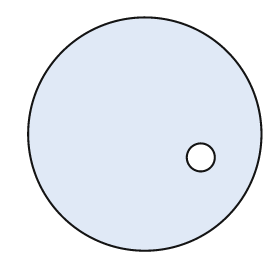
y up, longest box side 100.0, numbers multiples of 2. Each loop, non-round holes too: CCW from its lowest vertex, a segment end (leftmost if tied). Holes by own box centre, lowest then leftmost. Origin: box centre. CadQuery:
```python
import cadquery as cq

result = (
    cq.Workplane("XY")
    .moveTo(0.0, 0.0)
    .circle(50.0)
    .moveTo(24.0, -10.0)
    .circle(6.0)
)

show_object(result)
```